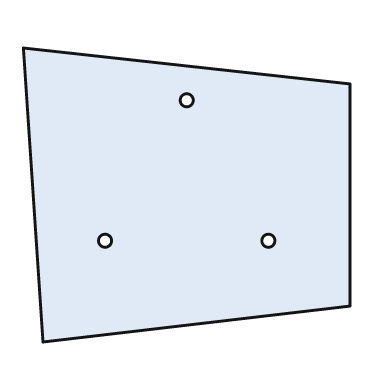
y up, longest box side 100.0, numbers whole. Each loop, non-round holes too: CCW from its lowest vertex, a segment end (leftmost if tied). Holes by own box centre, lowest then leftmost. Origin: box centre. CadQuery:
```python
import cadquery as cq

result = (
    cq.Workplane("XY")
    .moveTo(-44.0, -45.0)
    .lineTo(50.0, -34.0)
    .lineTo(50.0, 34.0)
    .lineTo(-50.0, 45.0)
    .close()
    .moveTo(-25.0, -14.0)
    .circle(2.0)
    .moveTo(25.0, -14.0)
    .circle(2.0)
    .moveTo(0.0, 29.0)
    .circle(2.0)
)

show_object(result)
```